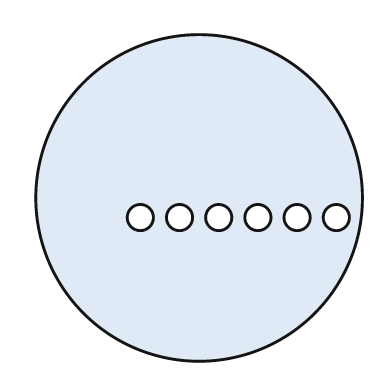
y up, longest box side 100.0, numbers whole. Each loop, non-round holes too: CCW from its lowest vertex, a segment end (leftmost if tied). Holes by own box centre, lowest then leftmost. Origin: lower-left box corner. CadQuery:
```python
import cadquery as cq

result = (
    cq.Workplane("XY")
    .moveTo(50.0, 50.0)
    .circle(50.0)
    .moveTo(32.0, 44.0)
    .circle(4.0)
    .moveTo(44.0, 44.0)
    .circle(4.0)
    .moveTo(56.0, 44.0)
    .circle(4.0)
    .moveTo(68.0, 44.0)
    .circle(4.0)
    .moveTo(80.0, 44.0)
    .circle(4.0)
    .moveTo(92.0, 44.0)
    .circle(4.0)
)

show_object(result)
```